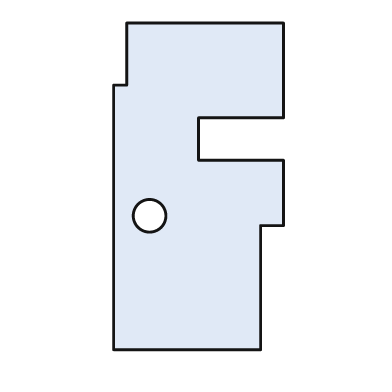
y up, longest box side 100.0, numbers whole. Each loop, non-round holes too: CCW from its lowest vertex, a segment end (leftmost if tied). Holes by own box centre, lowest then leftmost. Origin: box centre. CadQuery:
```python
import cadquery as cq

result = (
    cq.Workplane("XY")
    .moveTo(-26.0, -50.0)
    .lineTo(19.0, -50.0)
    .lineTo(19.0, -12.0)
    .lineTo(26.0, -12.0)
    .lineTo(26.0, 8.0)
    .lineTo(0.0, 8.0)
    .lineTo(0.0, 21.0)
    .lineTo(26.0, 21.0)
    .lineTo(26.0, 50.0)
    .lineTo(-22.0, 50.0)
    .lineTo(-22.0, 31.0)
    .lineTo(-26.0, 31.0)
    .close()
    .moveTo(-15.0, -9.0)
    .circle(5.0)
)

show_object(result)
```